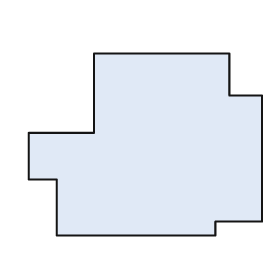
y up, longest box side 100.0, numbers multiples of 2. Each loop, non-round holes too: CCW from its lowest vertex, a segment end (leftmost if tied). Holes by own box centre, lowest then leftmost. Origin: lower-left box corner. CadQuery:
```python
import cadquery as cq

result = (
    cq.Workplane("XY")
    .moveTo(12.0, 0.0)
    .lineTo(80.0, 0.0)
    .lineTo(80.0, 6.0)
    .lineTo(100.0, 6.0)
    .lineTo(100.0, 60.0)
    .lineTo(86.0, 60.0)
    .lineTo(86.0, 78.0)
    .lineTo(28.0, 78.0)
    .lineTo(28.0, 44.0)
    .lineTo(0.0, 44.0)
    .lineTo(0.0, 24.0)
    .lineTo(12.0, 24.0)
    .close()
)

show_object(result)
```